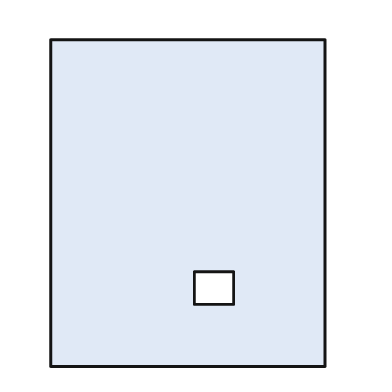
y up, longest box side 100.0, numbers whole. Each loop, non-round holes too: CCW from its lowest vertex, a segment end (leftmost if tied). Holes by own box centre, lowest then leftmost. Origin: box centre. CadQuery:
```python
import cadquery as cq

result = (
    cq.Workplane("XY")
    .moveTo(-42.0, -50.0)
    .lineTo(42.0, -50.0)
    .lineTo(42.0, 50.0)
    .lineTo(-42.0, 50.0)
    .close()
    .moveTo(2.0, -31.0)
    .lineTo(14.0, -31.0)
    .lineTo(14.0, -21.0)
    .lineTo(2.0, -21.0)
    .close()
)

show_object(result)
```